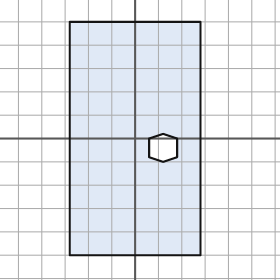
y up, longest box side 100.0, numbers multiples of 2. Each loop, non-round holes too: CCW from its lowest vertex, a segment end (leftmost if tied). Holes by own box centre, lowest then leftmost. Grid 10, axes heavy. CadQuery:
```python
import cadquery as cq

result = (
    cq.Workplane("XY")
    .moveTo(-28.0, -50.0)
    .lineTo(28.0, -50.0)
    .lineTo(28.0, 50.0)
    .lineTo(-28.0, 50.0)
    .close()
    .moveTo(12.0, -10.0)
    .lineTo(18.0, -8.0)
    .lineTo(18.0, 0.0)
    .lineTo(12.0, 2.0)
    .lineTo(6.0, 0.0)
    .lineTo(6.0, -8.0)
    .close()
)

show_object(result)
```